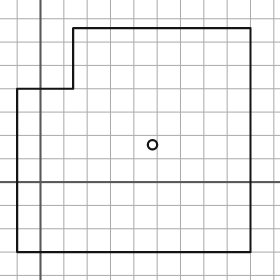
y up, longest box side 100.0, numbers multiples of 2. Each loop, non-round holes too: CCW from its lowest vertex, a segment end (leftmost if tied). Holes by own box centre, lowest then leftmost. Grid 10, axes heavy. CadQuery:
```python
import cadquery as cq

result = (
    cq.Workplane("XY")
    .moveTo(-10.0, -30.0)
    .lineTo(90.0, -30.0)
    .lineTo(90.0, 66.0)
    .lineTo(14.0, 66.0)
    .lineTo(14.0, 40.0)
    .lineTo(-10.0, 40.0)
    .close()
    .moveTo(48.0, 16.0)
    .circle(2.0)
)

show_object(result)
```